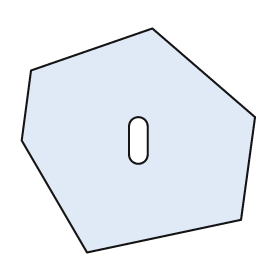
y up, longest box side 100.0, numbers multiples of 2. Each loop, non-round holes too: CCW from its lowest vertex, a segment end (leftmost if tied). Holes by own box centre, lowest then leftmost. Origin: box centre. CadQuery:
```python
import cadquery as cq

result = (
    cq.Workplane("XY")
    .moveTo(-22.0, -48.0)
    .lineTo(44.0, -34.0)
    .lineTo(50.0, 10.0)
    .lineTo(6.0, 48.0)
    .lineTo(-46.0, 30.0)
    .lineTo(-50.0, 0.0)
    .close()
    .moveTo(-4.0, -6.0)
    .threePointArc((0.0, -10.0), (4.0, -6.0))
    .lineTo(4.0, 6.0)
    .threePointArc((0.0, 10.0), (-4.0, 6.0))
    .close()
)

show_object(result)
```